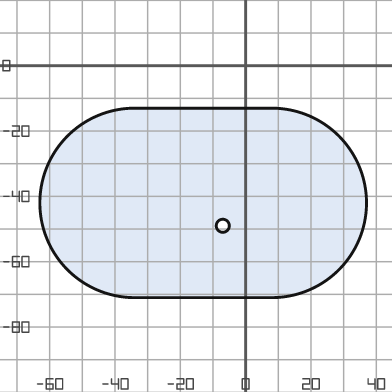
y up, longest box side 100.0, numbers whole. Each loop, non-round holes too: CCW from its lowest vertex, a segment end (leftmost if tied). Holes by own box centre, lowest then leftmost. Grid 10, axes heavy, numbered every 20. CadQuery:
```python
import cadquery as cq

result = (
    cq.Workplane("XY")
    .moveTo(-34.0, -71.0)
    .lineTo(8.0, -71.0)
    .threePointArc((37.0, -42.0), (8.0, -13.0))
    .lineTo(-34.0, -13.0)
    .threePointArc((-63.0, -42.0), (-34.0, -71.0))
    .close()
    .moveTo(-7.0, -49.0)
    .circle(2.0)
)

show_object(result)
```